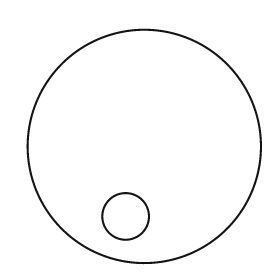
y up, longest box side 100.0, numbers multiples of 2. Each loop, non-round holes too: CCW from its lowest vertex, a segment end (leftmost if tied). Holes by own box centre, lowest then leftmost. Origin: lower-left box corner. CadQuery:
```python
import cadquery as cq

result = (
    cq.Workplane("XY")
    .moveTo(50.0, 50.0)
    .circle(50.0)
    .moveTo(42.0, 20.0)
    .circle(10.0)
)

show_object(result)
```